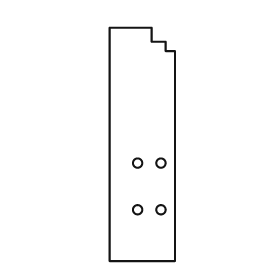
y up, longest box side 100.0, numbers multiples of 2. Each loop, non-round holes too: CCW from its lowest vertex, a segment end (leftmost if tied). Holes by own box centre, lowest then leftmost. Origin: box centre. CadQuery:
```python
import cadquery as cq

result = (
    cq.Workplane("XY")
    .moveTo(-14.0, -50.0)
    .lineTo(14.0, -50.0)
    .lineTo(14.0, 40.0)
    .lineTo(10.0, 40.0)
    .lineTo(10.0, 44.0)
    .lineTo(4.0, 44.0)
    .lineTo(4.0, 50.0)
    .lineTo(-14.0, 50.0)
    .close()
    .moveTo(-2.0, -28.0)
    .circle(2.0)
    .moveTo(8.0, -28.0)
    .circle(2.0)
    .moveTo(-2.0, -8.0)
    .circle(2.0)
    .moveTo(8.0, -8.0)
    .circle(2.0)
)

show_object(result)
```